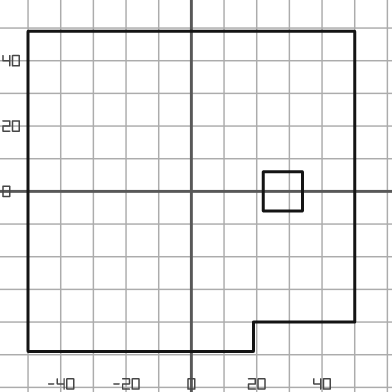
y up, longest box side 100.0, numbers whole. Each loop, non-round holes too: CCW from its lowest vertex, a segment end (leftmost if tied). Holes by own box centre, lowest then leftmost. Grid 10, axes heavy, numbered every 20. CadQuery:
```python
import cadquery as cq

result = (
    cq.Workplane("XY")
    .moveTo(-50.0, -49.0)
    .lineTo(19.0, -49.0)
    .lineTo(19.0, -40.0)
    .lineTo(50.0, -40.0)
    .lineTo(50.0, 49.0)
    .lineTo(-50.0, 49.0)
    .close()
    .moveTo(22.0, -6.0)
    .lineTo(34.0, -6.0)
    .lineTo(34.0, 6.0)
    .lineTo(22.0, 6.0)
    .close()
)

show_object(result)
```